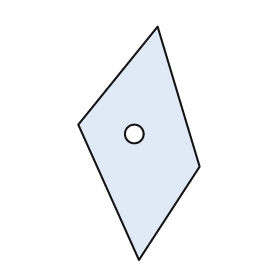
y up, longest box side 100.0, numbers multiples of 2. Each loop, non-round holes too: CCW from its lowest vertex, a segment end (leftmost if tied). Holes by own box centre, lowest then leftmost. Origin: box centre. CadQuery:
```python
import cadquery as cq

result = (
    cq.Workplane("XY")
    .moveTo(0.0, -50.0)
    .lineTo(26.0, -10.0)
    .lineTo(8.0, 50.0)
    .lineTo(-26.0, 8.0)
    .close()
    .moveTo(-2.0, 4.0)
    .circle(4.0)
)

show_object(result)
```